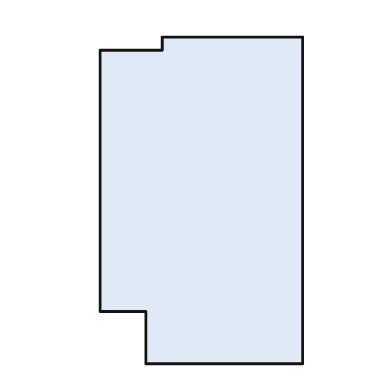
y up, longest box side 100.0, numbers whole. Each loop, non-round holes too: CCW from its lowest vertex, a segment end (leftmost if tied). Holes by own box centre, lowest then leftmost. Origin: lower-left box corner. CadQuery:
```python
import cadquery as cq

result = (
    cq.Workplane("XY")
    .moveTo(14.0, 0.0)
    .lineTo(62.0, 0.0)
    .lineTo(62.0, 100.0)
    .lineTo(19.0, 100.0)
    .lineTo(19.0, 96.0)
    .lineTo(0.0, 96.0)
    .lineTo(0.0, 16.0)
    .lineTo(14.0, 16.0)
    .close()
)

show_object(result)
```